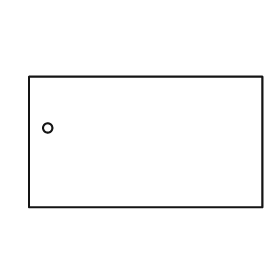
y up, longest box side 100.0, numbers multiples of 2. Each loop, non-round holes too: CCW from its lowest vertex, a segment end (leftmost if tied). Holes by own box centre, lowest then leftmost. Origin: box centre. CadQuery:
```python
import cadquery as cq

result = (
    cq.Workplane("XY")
    .moveTo(-50.0, -28.0)
    .lineTo(50.0, -28.0)
    .lineTo(50.0, 28.0)
    .lineTo(-50.0, 28.0)
    .close()
    .moveTo(-42.0, 6.0)
    .circle(2.0)
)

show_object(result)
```